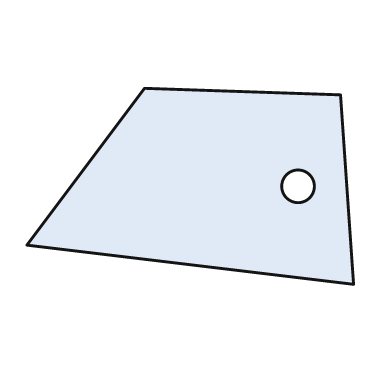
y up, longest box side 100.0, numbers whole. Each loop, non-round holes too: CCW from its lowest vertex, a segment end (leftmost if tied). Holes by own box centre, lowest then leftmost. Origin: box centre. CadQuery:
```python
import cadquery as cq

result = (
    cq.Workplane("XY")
    .moveTo(50.0, -30.0)
    .lineTo(46.0, 28.0)
    .lineTo(-14.0, 30.0)
    .lineTo(-50.0, -18.0)
    .close()
    .moveTo(33.0, 0.0)
    .circle(5.0)
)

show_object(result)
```